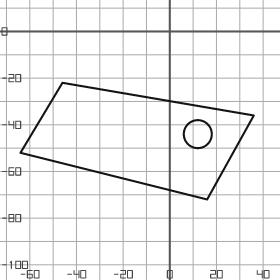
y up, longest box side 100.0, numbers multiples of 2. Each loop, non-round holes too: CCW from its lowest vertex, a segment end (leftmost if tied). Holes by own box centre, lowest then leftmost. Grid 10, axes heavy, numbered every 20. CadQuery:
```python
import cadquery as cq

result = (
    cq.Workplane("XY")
    .moveTo(16.0, -72.0)
    .lineTo(36.0, -36.0)
    .lineTo(-46.0, -22.0)
    .lineTo(-64.0, -52.0)
    .close()
    .moveTo(12.0, -44.0)
    .circle(6.0)
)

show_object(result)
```